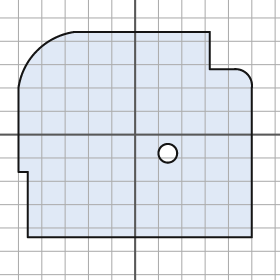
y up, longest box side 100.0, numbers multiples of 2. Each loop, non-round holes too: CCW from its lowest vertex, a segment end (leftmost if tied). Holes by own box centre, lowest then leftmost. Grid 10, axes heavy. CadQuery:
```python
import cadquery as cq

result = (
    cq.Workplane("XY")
    .moveTo(-46.0, -44.0)
    .lineTo(50.0, -44.0)
    .lineTo(50.0, 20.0)
    .threePointArc((48.0, 26.0), (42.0, 28.0))
    .lineTo(32.0, 28.0)
    .lineTo(32.0, 44.0)
    .lineTo(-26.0, 44.0)
    .threePointArc((-42.0, 36.0), (-50.0, 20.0))
    .lineTo(-50.0, -16.0)
    .lineTo(-46.0, -16.0)
    .close()
    .moveTo(14.0, -8.0)
    .circle(4.0)
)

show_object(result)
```